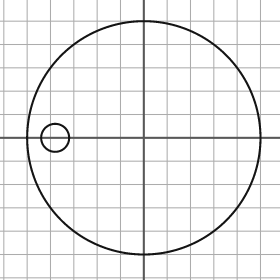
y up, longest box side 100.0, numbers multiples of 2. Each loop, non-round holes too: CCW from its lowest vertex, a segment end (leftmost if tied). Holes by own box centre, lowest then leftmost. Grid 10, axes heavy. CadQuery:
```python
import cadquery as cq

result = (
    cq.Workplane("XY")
    .moveTo(0.0, 0.0)
    .circle(50.0)
    .moveTo(-38.0, 0.0)
    .circle(6.0)
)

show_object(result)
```